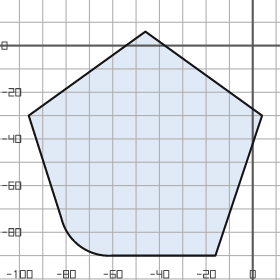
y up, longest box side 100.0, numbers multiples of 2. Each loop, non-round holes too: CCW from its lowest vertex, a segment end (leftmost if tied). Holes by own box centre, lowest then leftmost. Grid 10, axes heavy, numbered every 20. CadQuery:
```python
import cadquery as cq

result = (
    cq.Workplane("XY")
    .moveTo(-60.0, -90.0)
    .lineTo(-16.0, -90.0)
    .lineTo(4.0, -30.0)
    .lineTo(-46.0, 6.0)
    .lineTo(-96.0, -30.0)
    .lineTo(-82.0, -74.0)
    .threePointArc((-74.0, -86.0), (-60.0, -90.0))
    .close()
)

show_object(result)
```